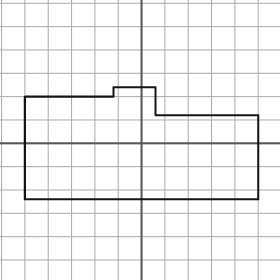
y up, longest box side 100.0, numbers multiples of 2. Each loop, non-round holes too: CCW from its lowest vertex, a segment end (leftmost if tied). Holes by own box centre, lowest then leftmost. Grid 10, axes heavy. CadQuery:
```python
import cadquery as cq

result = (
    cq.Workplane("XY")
    .moveTo(-50.0, -24.0)
    .lineTo(50.0, -24.0)
    .lineTo(50.0, 12.0)
    .lineTo(6.0, 12.0)
    .lineTo(6.0, 24.0)
    .lineTo(-12.0, 24.0)
    .lineTo(-12.0, 20.0)
    .lineTo(-50.0, 20.0)
    .close()
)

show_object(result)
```